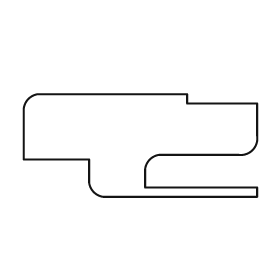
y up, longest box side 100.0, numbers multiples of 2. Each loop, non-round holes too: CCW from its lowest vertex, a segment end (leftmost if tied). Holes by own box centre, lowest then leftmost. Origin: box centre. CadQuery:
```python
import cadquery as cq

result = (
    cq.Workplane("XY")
    .moveTo(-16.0, -22.0)
    .lineTo(50.0, -22.0)
    .lineTo(50.0, -18.0)
    .lineTo(2.0, -18.0)
    .lineTo(2.0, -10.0)
    .threePointArc((4.0, -6.0), (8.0, -4.0))
    .lineTo(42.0, -4.0)
    .threePointArc((48.0, -2.0), (50.0, 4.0))
    .lineTo(50.0, 18.0)
    .lineTo(20.0, 18.0)
    .lineTo(20.0, 22.0)
    .lineTo(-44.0, 22.0)
    .threePointArc((-48.0, 20.0), (-50.0, 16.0))
    .lineTo(-50.0, -6.0)
    .lineTo(-22.0, -6.0)
    .lineTo(-22.0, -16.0)
    .threePointArc((-20.0, -20.0), (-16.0, -22.0))
    .close()
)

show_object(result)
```